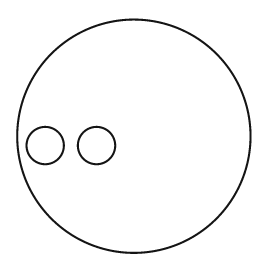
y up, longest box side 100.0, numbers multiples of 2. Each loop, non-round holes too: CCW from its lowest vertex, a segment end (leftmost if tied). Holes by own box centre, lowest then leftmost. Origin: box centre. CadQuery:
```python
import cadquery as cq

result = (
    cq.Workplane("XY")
    .moveTo(0.0, 0.0)
    .circle(50.0)
    .moveTo(-38.0, -4.0)
    .circle(8.0)
    .moveTo(-16.0, -4.0)
    .circle(8.0)
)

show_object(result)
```